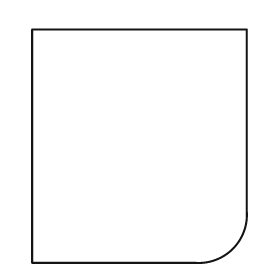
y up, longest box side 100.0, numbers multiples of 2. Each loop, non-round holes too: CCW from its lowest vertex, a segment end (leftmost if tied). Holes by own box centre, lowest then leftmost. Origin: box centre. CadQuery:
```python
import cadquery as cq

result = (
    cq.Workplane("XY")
    .moveTo(-46.0, -50.0)
    .lineTo(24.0, -50.0)
    .threePointArc((40.0, -44.0), (46.0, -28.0))
    .lineTo(46.0, 50.0)
    .lineTo(-46.0, 50.0)
    .close()
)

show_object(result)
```